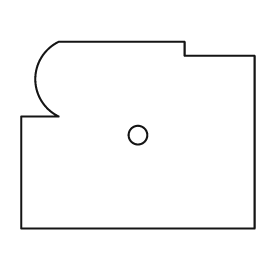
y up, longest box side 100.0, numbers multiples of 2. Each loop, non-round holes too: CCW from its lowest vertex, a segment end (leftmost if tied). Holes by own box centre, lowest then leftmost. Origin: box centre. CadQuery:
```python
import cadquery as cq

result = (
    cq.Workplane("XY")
    .moveTo(-50.0, -40.0)
    .lineTo(50.0, -40.0)
    .lineTo(50.0, 34.0)
    .lineTo(20.0, 34.0)
    .lineTo(20.0, 40.0)
    .lineTo(-34.0, 40.0)
    .threePointArc((-44.0, 24.0), (-34.0, 8.0))
    .lineTo(-50.0, 8.0)
    .close()
    .moveTo(0.0, 0.0)
    .circle(4.0)
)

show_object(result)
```